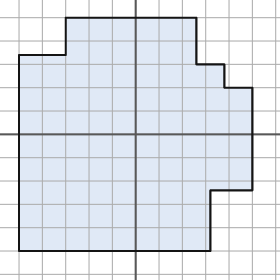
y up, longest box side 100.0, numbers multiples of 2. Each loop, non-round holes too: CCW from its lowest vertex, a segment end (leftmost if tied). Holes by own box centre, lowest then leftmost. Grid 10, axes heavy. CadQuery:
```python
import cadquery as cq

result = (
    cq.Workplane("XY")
    .moveTo(-50.0, -50.0)
    .lineTo(32.0, -50.0)
    .lineTo(32.0, -24.0)
    .lineTo(50.0, -24.0)
    .lineTo(50.0, 20.0)
    .lineTo(38.0, 20.0)
    .lineTo(38.0, 30.0)
    .lineTo(26.0, 30.0)
    .lineTo(26.0, 50.0)
    .lineTo(-30.0, 50.0)
    .lineTo(-30.0, 34.0)
    .lineTo(-50.0, 34.0)
    .close()
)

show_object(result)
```